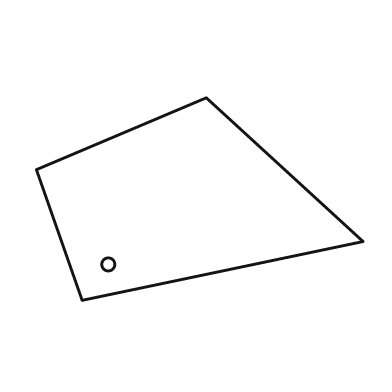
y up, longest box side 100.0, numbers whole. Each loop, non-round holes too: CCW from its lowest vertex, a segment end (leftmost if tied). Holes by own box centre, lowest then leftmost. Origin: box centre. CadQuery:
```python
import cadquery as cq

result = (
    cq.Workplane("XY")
    .moveTo(-36.0, -31.0)
    .lineTo(50.0, -13.0)
    .lineTo(2.0, 31.0)
    .lineTo(-50.0, 9.0)
    .close()
    .moveTo(-28.0, -20.0)
    .circle(2.0)
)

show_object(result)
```